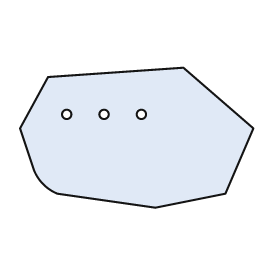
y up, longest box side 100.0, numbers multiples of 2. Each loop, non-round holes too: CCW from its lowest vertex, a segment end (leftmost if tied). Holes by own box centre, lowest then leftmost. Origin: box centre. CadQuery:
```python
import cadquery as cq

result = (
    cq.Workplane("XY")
    .moveTo(8.0, -30.0)
    .lineTo(38.0, -24.0)
    .lineTo(50.0, 4.0)
    .lineTo(20.0, 30.0)
    .lineTo(-38.0, 26.0)
    .lineTo(-50.0, 4.0)
    .lineTo(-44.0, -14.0)
    .threePointArc((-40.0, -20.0), (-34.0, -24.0))
    .close()
    .moveTo(-30.0, 10.0)
    .circle(2.0)
    .moveTo(-14.0, 10.0)
    .circle(2.0)
    .moveTo(2.0, 10.0)
    .circle(2.0)
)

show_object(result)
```